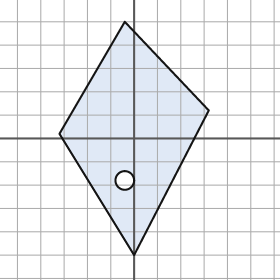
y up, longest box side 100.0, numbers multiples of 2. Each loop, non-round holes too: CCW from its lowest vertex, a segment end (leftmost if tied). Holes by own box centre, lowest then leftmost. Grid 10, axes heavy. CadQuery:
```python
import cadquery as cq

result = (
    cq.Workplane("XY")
    .moveTo(0.0, -50.0)
    .lineTo(32.0, 12.0)
    .lineTo(-4.0, 50.0)
    .lineTo(-32.0, 2.0)
    .close()
    .moveTo(-4.0, -18.0)
    .circle(4.0)
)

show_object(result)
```